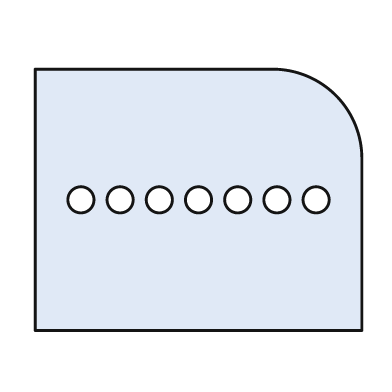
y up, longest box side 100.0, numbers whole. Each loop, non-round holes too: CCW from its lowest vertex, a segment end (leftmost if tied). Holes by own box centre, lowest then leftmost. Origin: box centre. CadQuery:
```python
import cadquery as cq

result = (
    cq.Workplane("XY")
    .moveTo(-50.0, -40.0)
    .lineTo(50.0, -40.0)
    .lineTo(50.0, 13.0)
    .threePointArc((42.0, 32.0), (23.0, 40.0))
    .lineTo(-50.0, 40.0)
    .close()
    .moveTo(-36.0, 0.0)
    .circle(4.0)
    .moveTo(-24.0, 0.0)
    .circle(4.0)
    .moveTo(-12.0, 0.0)
    .circle(4.0)
    .moveTo(0.0, 0.0)
    .circle(4.0)
    .moveTo(12.0, 0.0)
    .circle(4.0)
    .moveTo(24.0, 0.0)
    .circle(4.0)
    .moveTo(36.0, 0.0)
    .circle(4.0)
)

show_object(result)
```